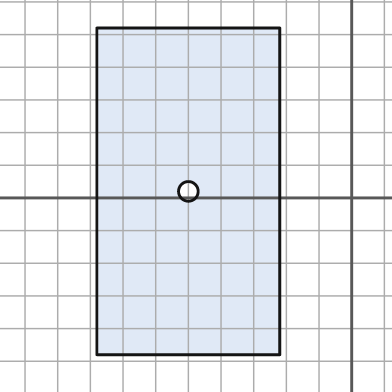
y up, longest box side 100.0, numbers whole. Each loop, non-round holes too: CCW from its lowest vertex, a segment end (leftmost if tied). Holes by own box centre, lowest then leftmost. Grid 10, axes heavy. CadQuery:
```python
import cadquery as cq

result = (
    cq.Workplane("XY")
    .moveTo(-78.0, -48.0)
    .lineTo(-22.0, -48.0)
    .lineTo(-22.0, 52.0)
    .lineTo(-78.0, 52.0)
    .close()
    .moveTo(-50.0, 2.0)
    .circle(3.0)
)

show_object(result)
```